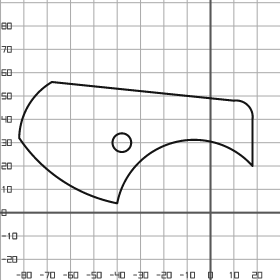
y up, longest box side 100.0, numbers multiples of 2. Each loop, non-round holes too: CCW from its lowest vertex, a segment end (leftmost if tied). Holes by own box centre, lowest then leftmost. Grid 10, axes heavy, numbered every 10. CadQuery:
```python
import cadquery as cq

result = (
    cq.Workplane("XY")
    .moveTo(-40.0, 4.0)
    .threePointArc((-16.0, 30.0), (18.0, 20.0))
    .lineTo(18.0, 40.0)
    .threePointArc((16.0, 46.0), (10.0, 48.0))
    .lineTo(-68.0, 56.0)
    .threePointArc((-78.0, 46.0), (-82.0, 32.0))
    .threePointArc((-64.0, 14.0), (-40.0, 4.0))
    .close()
    .moveTo(-38.0, 30.0)
    .circle(4.0)
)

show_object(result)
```